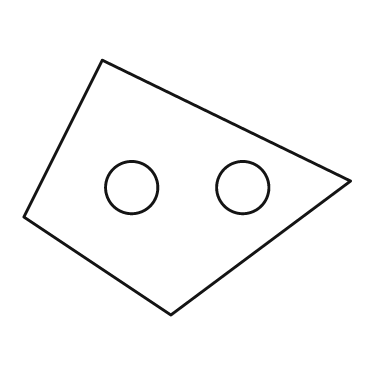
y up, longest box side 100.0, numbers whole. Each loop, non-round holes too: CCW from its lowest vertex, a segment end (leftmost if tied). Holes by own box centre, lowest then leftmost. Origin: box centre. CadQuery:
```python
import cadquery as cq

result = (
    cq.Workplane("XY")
    .moveTo(-5.0, -39.0)
    .lineTo(50.0, 2.0)
    .lineTo(-26.0, 39.0)
    .lineTo(-50.0, -9.0)
    .close()
    .moveTo(-17.0, 0.0)
    .circle(8.0)
    .moveTo(17.0, 0.0)
    .circle(8.0)
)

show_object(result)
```